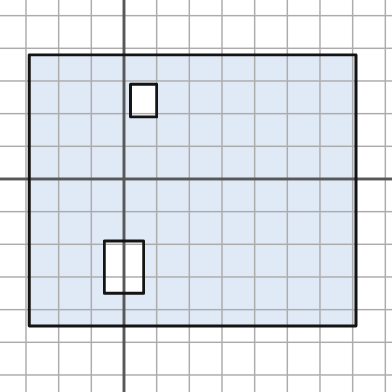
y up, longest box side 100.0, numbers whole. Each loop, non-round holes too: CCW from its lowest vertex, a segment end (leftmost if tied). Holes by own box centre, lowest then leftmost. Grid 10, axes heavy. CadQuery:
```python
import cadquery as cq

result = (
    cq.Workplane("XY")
    .moveTo(-29.0, -45.0)
    .lineTo(71.0, -45.0)
    .lineTo(71.0, 38.0)
    .lineTo(-29.0, 38.0)
    .close()
    .moveTo(-6.0, -35.0)
    .lineTo(6.0, -35.0)
    .lineTo(6.0, -19.0)
    .lineTo(-6.0, -19.0)
    .close()
    .moveTo(2.0, 19.0)
    .lineTo(10.0, 19.0)
    .lineTo(10.0, 29.0)
    .lineTo(2.0, 29.0)
    .close()
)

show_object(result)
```